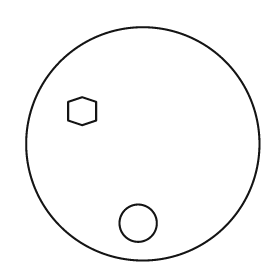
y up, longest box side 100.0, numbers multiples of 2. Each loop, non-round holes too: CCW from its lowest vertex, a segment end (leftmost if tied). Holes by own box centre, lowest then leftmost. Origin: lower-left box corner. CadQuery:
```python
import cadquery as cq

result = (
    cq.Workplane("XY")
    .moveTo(50.0, 50.0)
    .circle(50.0)
    .moveTo(48.0, 16.0)
    .circle(8.0)
    .moveTo(24.0, 58.0)
    .lineTo(30.0, 60.0)
    .lineTo(30.0, 68.0)
    .lineTo(24.0, 70.0)
    .lineTo(18.0, 68.0)
    .lineTo(18.0, 60.0)
    .close()
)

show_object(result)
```